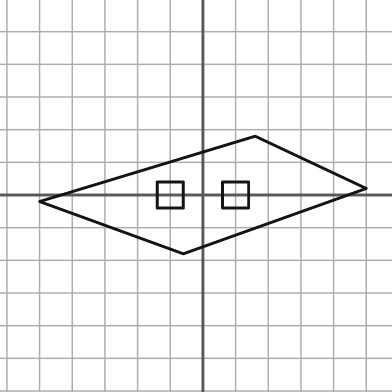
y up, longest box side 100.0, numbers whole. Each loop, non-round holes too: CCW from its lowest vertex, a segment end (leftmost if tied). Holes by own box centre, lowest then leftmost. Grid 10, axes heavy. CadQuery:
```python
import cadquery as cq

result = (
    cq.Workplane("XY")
    .moveTo(-6.0, -18.0)
    .lineTo(50.0, 2.0)
    .lineTo(16.0, 18.0)
    .lineTo(-50.0, -2.0)
    .close()
    .moveTo(-14.0, -4.0)
    .lineTo(-6.0, -4.0)
    .lineTo(-6.0, 4.0)
    .lineTo(-14.0, 4.0)
    .close()
    .moveTo(6.0, -4.0)
    .lineTo(14.0, -4.0)
    .lineTo(14.0, 4.0)
    .lineTo(6.0, 4.0)
    .close()
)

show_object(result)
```